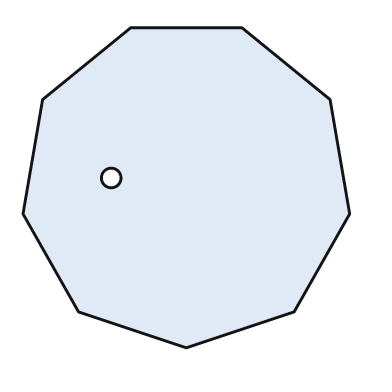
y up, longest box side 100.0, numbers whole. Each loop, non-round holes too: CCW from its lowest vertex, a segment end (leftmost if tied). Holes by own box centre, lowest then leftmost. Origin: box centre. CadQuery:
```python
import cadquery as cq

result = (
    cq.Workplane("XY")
    .moveTo(0.0, -49.0)
    .lineTo(33.0, -38.0)
    .lineTo(50.0, -8.0)
    .lineTo(44.0, 27.0)
    .lineTo(17.0, 49.0)
    .lineTo(-17.0, 49.0)
    .lineTo(-44.0, 27.0)
    .lineTo(-50.0, -8.0)
    .lineTo(-33.0, -38.0)
    .close()
    .moveTo(-23.0, 3.0)
    .circle(3.0)
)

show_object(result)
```